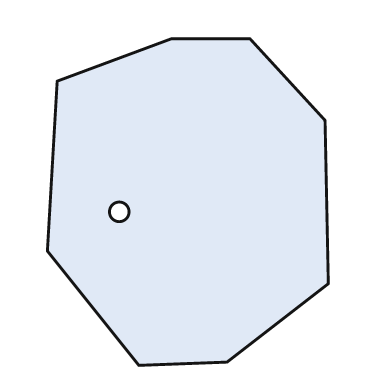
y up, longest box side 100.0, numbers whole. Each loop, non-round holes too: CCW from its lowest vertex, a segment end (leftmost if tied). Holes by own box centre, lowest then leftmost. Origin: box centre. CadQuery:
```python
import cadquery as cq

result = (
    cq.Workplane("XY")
    .moveTo(-15.0, -50.0)
    .lineTo(12.0, -49.0)
    .lineTo(43.0, -25.0)
    .lineTo(42.0, 25.0)
    .lineTo(19.0, 50.0)
    .lineTo(-5.0, 50.0)
    .lineTo(-40.0, 37.0)
    .lineTo(-43.0, -15.0)
    .close()
    .moveTo(-21.0, -3.0)
    .circle(3.0)
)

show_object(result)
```